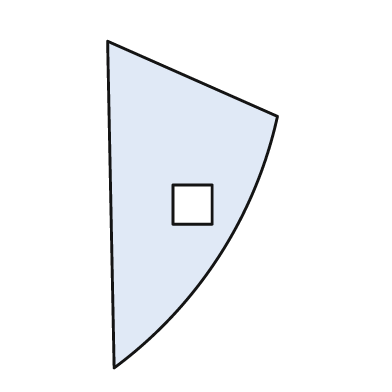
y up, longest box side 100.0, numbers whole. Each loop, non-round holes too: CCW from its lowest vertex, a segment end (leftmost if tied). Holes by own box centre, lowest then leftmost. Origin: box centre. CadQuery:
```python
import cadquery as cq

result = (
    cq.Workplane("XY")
    .moveTo(-24.0, -50.0)
    .threePointArc((8.0, -16.0), (26.0, 27.0))
    .lineTo(-26.0, 50.0)
    .close()
    .moveTo(-6.0, -6.0)
    .lineTo(6.0, -6.0)
    .lineTo(6.0, 6.0)
    .lineTo(-6.0, 6.0)
    .close()
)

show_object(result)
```